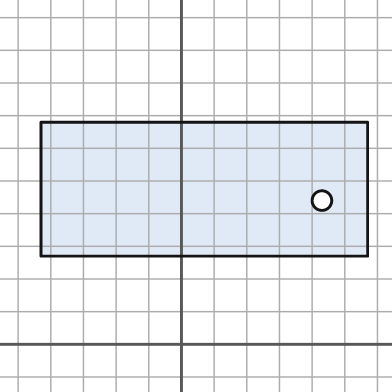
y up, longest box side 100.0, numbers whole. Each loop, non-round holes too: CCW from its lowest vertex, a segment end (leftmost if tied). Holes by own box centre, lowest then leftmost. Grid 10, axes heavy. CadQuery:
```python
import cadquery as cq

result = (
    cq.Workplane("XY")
    .moveTo(-43.0, 27.0)
    .lineTo(57.0, 27.0)
    .lineTo(57.0, 68.0)
    .lineTo(-43.0, 68.0)
    .close()
    .moveTo(43.0, 44.0)
    .circle(3.0)
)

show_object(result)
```